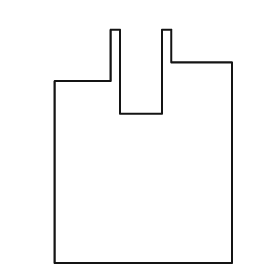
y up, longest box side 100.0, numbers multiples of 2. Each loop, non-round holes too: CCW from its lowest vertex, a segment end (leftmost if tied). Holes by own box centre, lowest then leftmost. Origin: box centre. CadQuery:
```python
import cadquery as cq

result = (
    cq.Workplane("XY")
    .moveTo(-38.0, -50.0)
    .lineTo(38.0, -50.0)
    .lineTo(38.0, 36.0)
    .lineTo(12.0, 36.0)
    .lineTo(12.0, 50.0)
    .lineTo(8.0, 50.0)
    .lineTo(8.0, 14.0)
    .lineTo(-10.0, 14.0)
    .lineTo(-10.0, 50.0)
    .lineTo(-14.0, 50.0)
    .lineTo(-14.0, 28.0)
    .lineTo(-38.0, 28.0)
    .close()
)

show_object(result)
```